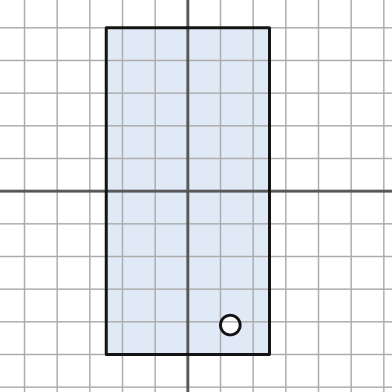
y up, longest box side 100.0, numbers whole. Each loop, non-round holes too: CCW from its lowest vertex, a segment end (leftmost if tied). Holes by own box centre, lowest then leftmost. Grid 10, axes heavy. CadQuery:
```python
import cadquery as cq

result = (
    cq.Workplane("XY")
    .moveTo(-25.0, -50.0)
    .lineTo(25.0, -50.0)
    .lineTo(25.0, 50.0)
    .lineTo(-25.0, 50.0)
    .close()
    .moveTo(13.0, -41.0)
    .circle(3.0)
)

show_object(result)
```